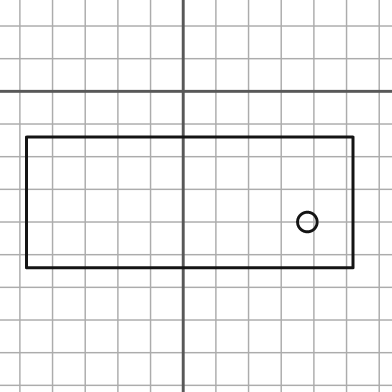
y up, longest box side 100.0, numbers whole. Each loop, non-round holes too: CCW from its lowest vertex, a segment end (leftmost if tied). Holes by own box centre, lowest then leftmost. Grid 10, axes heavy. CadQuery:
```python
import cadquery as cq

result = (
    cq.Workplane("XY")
    .moveTo(-48.0, -54.0)
    .lineTo(52.0, -54.0)
    .lineTo(52.0, -14.0)
    .lineTo(-48.0, -14.0)
    .close()
    .moveTo(38.0, -40.0)
    .circle(3.0)
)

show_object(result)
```